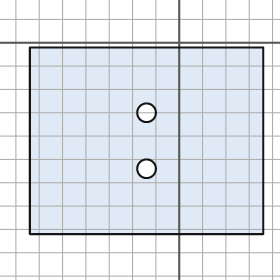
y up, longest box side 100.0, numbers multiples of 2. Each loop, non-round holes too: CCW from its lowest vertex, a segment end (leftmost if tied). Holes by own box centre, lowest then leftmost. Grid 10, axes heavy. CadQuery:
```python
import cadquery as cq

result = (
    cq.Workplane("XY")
    .moveTo(-64.0, -82.0)
    .lineTo(36.0, -82.0)
    .lineTo(36.0, -2.0)
    .lineTo(-64.0, -2.0)
    .close()
    .moveTo(-14.0, -54.0)
    .circle(4.0)
    .moveTo(-14.0, -30.0)
    .circle(4.0)
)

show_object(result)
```